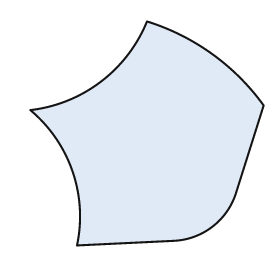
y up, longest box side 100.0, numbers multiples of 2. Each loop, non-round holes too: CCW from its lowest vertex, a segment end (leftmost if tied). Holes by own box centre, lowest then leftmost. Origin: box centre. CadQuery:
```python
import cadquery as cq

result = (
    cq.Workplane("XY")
    .moveTo(-30.0, -48.0)
    .lineTo(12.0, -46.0)
    .threePointArc((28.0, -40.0), (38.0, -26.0))
    .lineTo(50.0, 12.0)
    .threePointArc((28.0, 34.0), (0.0, 48.0))
    .threePointArc((-20.0, 22.0), (-50.0, 10.0))
    .threePointArc((-32.0, -16.0), (-30.0, -48.0))
    .close()
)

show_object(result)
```